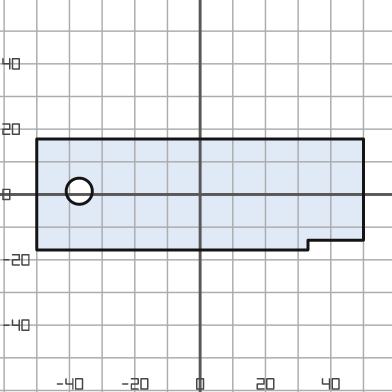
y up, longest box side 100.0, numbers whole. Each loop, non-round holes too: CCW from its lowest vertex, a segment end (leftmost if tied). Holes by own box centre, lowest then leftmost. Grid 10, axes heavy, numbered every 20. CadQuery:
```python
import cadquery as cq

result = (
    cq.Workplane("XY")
    .moveTo(-50.0, -17.0)
    .lineTo(33.0, -17.0)
    .lineTo(33.0, -14.0)
    .lineTo(50.0, -14.0)
    .lineTo(50.0, 17.0)
    .lineTo(-50.0, 17.0)
    .close()
    .moveTo(-37.0, 1.0)
    .circle(4.0)
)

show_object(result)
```